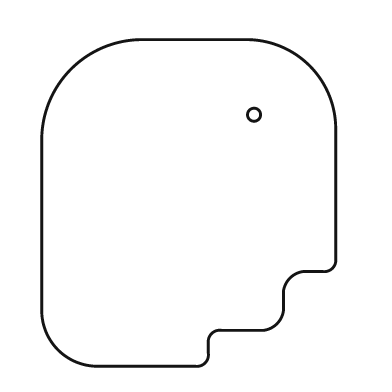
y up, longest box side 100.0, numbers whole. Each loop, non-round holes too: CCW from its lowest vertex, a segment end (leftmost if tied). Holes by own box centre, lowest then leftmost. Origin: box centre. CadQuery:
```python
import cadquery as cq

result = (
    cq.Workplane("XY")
    .moveTo(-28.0, -50.0)
    .lineTo(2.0, -50.0)
    .threePointArc((5.0, -49.0), (6.0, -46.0))
    .lineTo(6.0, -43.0)
    .threePointArc((7.0, -40.0), (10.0, -39.0))
    .lineTo(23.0, -39.0)
    .threePointArc((27.0, -37.0), (29.0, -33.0))
    .lineTo(29.0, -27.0)
    .threePointArc((31.0, -23.0), (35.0, -21.0))
    .lineTo(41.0, -21.0)
    .threePointArc((44.0, -20.0), (45.0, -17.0))
    .lineTo(45.0, 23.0)
    .threePointArc((37.0, 42.0), (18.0, 50.0))
    .lineTo(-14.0, 50.0)
    .threePointArc((-36.0, 41.0), (-45.0, 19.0))
    .lineTo(-45.0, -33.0)
    .threePointArc((-40.0, -45.0), (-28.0, -50.0))
    .close()
    .moveTo(20.0, 27.0)
    .circle(2.0)
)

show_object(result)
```